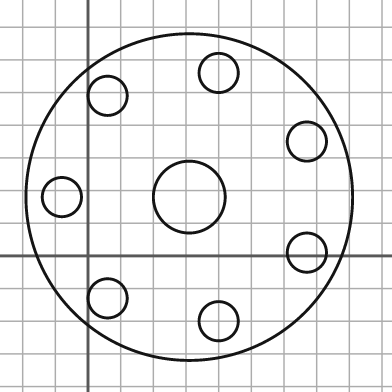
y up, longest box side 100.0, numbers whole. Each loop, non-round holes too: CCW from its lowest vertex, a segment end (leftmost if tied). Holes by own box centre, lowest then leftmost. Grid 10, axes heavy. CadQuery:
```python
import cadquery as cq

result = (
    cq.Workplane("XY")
    .moveTo(31.0, 18.0)
    .circle(50.0)
    .moveTo(40.0, -20.0)
    .circle(6.0)
    .moveTo(6.0, -13.0)
    .circle(6.0)
    .moveTo(67.0, 1.0)
    .circle(6.0)
    .moveTo(-8.0, 18.0)
    .circle(6.0)
    .moveTo(31.0, 18.0)
    .circle(11.0)
    .moveTo(67.0, 35.0)
    .circle(6.0)
    .moveTo(6.0, 49.0)
    .circle(6.0)
    .moveTo(40.0, 56.0)
    .circle(6.0)
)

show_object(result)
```